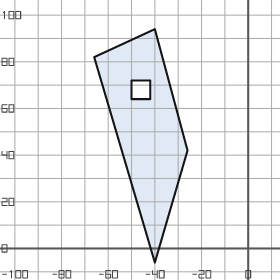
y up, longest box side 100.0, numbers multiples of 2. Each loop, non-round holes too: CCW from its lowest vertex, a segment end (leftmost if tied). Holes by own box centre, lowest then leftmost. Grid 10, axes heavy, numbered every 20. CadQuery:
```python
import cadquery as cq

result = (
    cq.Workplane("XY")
    .moveTo(-40.0, -6.0)
    .lineTo(-26.0, 42.0)
    .lineTo(-40.0, 94.0)
    .lineTo(-66.0, 82.0)
    .close()
    .moveTo(-50.0, 64.0)
    .lineTo(-42.0, 64.0)
    .lineTo(-42.0, 72.0)
    .lineTo(-50.0, 72.0)
    .close()
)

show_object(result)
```